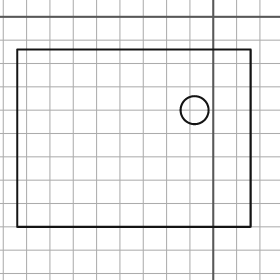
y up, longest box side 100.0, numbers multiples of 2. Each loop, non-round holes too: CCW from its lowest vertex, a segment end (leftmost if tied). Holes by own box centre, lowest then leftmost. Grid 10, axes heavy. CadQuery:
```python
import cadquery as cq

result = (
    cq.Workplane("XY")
    .moveTo(-84.0, -90.0)
    .lineTo(16.0, -90.0)
    .lineTo(16.0, -14.0)
    .lineTo(-84.0, -14.0)
    .close()
    .moveTo(-8.0, -40.0)
    .circle(6.0)
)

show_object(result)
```